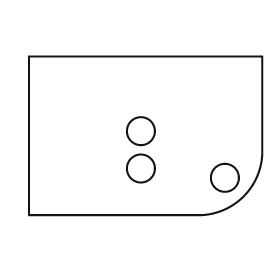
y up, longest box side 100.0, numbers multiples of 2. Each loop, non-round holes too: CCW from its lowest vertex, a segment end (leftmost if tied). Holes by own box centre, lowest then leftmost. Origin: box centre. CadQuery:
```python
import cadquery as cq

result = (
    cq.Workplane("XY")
    .moveTo(-50.0, -34.0)
    .lineTo(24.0, -34.0)
    .threePointArc((42.0, -26.0), (50.0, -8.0))
    .lineTo(50.0, 34.0)
    .lineTo(-50.0, 34.0)
    .close()
    .moveTo(34.0, -18.0)
    .circle(6.0)
    .moveTo(-2.0, -14.0)
    .circle(6.0)
    .moveTo(-2.0, 2.0)
    .circle(6.0)
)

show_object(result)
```